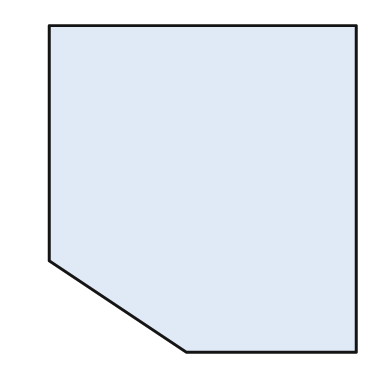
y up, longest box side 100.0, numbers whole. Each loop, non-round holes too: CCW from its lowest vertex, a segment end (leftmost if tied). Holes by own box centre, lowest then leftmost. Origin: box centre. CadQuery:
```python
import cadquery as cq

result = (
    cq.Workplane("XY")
    .moveTo(-5.0, -50.0)
    .lineTo(47.0, -50.0)
    .lineTo(47.0, 50.0)
    .lineTo(-47.0, 50.0)
    .lineTo(-47.0, -22.0)
    .close()
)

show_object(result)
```